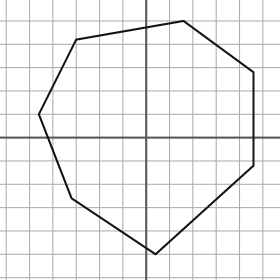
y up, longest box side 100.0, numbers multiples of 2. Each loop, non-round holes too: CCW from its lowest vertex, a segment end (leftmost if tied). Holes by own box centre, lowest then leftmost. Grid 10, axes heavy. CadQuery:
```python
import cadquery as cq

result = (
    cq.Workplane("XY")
    .moveTo(4.0, -50.0)
    .lineTo(46.0, -12.0)
    .lineTo(46.0, 28.0)
    .lineTo(16.0, 50.0)
    .lineTo(-30.0, 42.0)
    .lineTo(-46.0, 10.0)
    .lineTo(-32.0, -26.0)
    .close()
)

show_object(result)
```